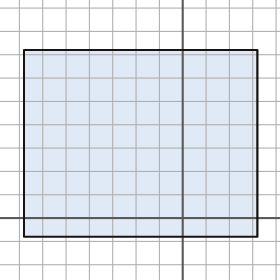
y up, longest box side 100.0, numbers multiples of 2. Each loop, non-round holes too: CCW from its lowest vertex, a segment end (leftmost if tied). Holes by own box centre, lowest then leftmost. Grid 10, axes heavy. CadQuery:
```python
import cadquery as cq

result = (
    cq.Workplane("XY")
    .moveTo(-68.0, -8.0)
    .lineTo(32.0, -8.0)
    .lineTo(32.0, 72.0)
    .lineTo(-68.0, 72.0)
    .close()
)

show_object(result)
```